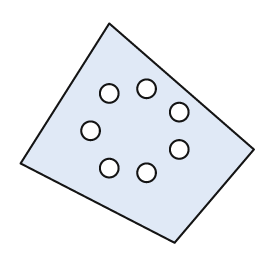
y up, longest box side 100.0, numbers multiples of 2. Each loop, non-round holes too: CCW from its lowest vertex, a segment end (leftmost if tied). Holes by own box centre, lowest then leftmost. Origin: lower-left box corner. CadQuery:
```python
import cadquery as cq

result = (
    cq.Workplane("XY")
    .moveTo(66.0, 0.0)
    .lineTo(100.0, 40.0)
    .lineTo(38.0, 94.0)
    .lineTo(0.0, 34.0)
    .close()
    .moveTo(54.0, 30.0)
    .circle(4.0)
    .moveTo(38.0, 32.0)
    .circle(4.0)
    .moveTo(68.0, 40.0)
    .circle(4.0)
    .moveTo(30.0, 48.0)
    .circle(4.0)
    .moveTo(68.0, 56.0)
    .circle(4.0)
    .moveTo(38.0, 64.0)
    .circle(4.0)
    .moveTo(54.0, 66.0)
    .circle(4.0)
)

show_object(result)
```